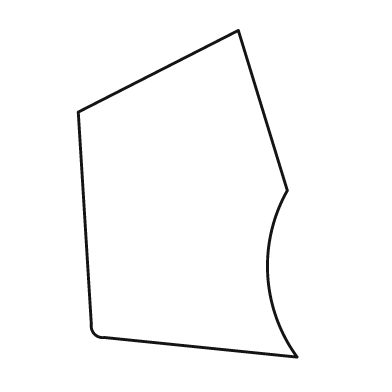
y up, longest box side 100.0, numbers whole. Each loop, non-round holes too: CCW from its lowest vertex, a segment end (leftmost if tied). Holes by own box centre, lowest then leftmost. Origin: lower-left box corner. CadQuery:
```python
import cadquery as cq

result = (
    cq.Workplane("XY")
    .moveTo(67.0, 0.0)
    .threePointArc((58.0, 25.0), (64.0, 51.0))
    .lineTo(49.0, 100.0)
    .lineTo(0.0, 75.0)
    .lineTo(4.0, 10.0)
    .threePointArc((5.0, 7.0), (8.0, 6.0))
    .close()
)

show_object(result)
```